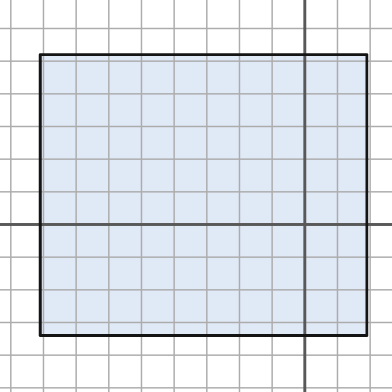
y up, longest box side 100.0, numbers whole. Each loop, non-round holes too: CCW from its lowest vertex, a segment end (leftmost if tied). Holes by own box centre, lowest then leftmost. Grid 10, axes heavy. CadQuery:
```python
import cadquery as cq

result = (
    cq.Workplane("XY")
    .moveTo(-81.0, -34.0)
    .lineTo(19.0, -34.0)
    .lineTo(19.0, 52.0)
    .lineTo(-81.0, 52.0)
    .close()
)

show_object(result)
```